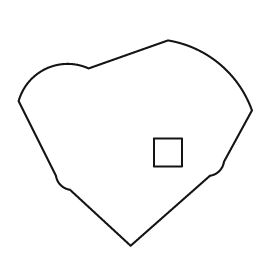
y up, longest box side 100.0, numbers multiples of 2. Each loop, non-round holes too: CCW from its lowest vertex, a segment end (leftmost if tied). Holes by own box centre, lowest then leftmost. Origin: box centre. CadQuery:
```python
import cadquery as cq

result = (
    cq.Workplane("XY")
    .moveTo(-2.0, -44.0)
    .lineTo(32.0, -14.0)
    .threePointArc((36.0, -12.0), (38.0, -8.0))
    .lineTo(50.0, 14.0)
    .threePointArc((36.0, 34.0), (14.0, 44.0))
    .lineTo(-20.0, 32.0)
    .threePointArc((-38.0, 32.0), (-50.0, 18.0))
    .lineTo(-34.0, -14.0)
    .threePointArc((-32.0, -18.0), (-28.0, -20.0))
    .close()
    .moveTo(8.0, -10.0)
    .lineTo(20.0, -10.0)
    .lineTo(20.0, 2.0)
    .lineTo(8.0, 2.0)
    .close()
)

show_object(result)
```